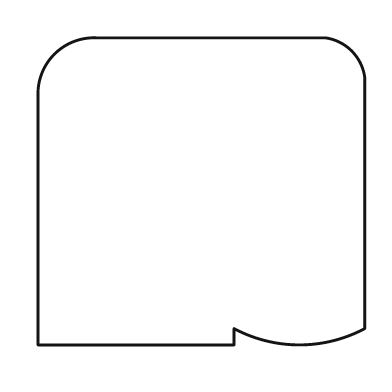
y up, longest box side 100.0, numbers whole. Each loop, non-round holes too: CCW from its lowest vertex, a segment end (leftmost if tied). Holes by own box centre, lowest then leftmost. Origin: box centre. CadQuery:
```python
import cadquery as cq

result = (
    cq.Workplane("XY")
    .moveTo(-50.0, -47.0)
    .lineTo(10.0, -47.0)
    .lineTo(10.0, -42.0)
    .threePointArc((30.0, -47.0), (50.0, -42.0))
    .lineTo(50.0, 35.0)
    .threePointArc((46.0, 43.0), (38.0, 47.0))
    .lineTo(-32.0, 47.0)
    .threePointArc((-45.0, 42.0), (-50.0, 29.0))
    .close()
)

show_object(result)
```